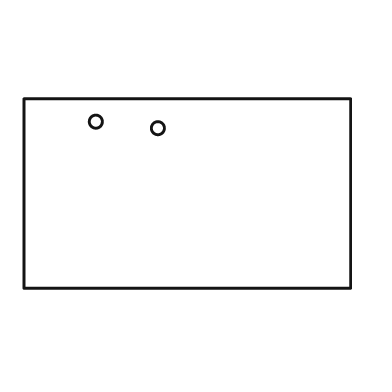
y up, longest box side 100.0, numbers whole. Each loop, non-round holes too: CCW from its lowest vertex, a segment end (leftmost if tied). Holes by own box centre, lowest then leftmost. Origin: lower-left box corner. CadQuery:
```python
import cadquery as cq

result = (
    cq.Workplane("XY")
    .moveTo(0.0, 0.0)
    .lineTo(100.0, 0.0)
    .lineTo(100.0, 58.0)
    .lineTo(0.0, 58.0)
    .close()
    .moveTo(41.0, 49.0)
    .circle(2.0)
    .moveTo(22.0, 51.0)
    .circle(2.0)
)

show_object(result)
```